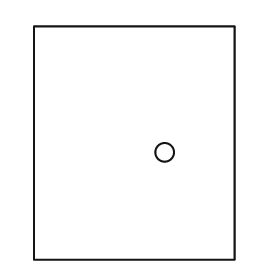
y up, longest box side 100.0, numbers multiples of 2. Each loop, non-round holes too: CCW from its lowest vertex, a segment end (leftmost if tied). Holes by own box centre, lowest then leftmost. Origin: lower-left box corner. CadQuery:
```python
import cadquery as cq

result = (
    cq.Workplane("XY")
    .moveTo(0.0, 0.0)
    .lineTo(86.0, 0.0)
    .lineTo(86.0, 100.0)
    .lineTo(0.0, 100.0)
    .close()
    .moveTo(56.0, 46.0)
    .circle(4.0)
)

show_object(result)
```